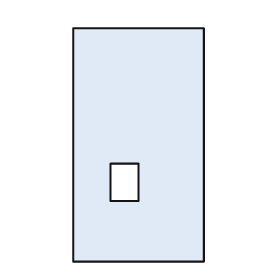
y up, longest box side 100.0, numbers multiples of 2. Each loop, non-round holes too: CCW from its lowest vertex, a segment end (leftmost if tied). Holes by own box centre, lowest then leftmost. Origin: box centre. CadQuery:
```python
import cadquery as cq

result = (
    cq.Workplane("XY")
    .moveTo(-28.0, -50.0)
    .lineTo(28.0, -50.0)
    .lineTo(28.0, 50.0)
    .lineTo(-28.0, 50.0)
    .close()
    .moveTo(-12.0, -24.0)
    .lineTo(0.0, -24.0)
    .lineTo(0.0, -8.0)
    .lineTo(-12.0, -8.0)
    .close()
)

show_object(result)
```